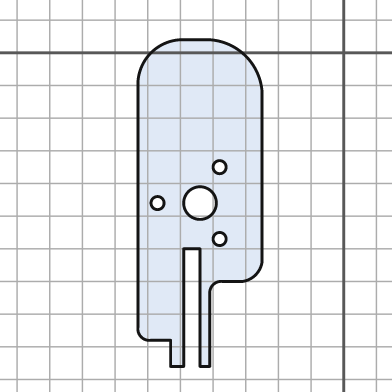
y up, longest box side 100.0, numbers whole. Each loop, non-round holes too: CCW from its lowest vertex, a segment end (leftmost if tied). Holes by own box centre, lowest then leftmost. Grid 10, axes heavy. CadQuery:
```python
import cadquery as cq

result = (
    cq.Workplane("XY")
    .moveTo(-53.0, -96.0)
    .lineTo(-49.0, -96.0)
    .lineTo(-49.0, -60.0)
    .lineTo(-44.0, -60.0)
    .lineTo(-44.0, -96.0)
    .lineTo(-41.0, -96.0)
    .lineTo(-41.0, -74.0)
    .threePointArc((-40.0, -71.0), (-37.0, -70.0))
    .lineTo(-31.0, -70.0)
    .threePointArc((-27.0, -68.0), (-25.0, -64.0))
    .lineTo(-25.0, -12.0)
    .threePointArc((-30.0, -1.0), (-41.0, 4.0))
    .lineTo(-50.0, 4.0)
    .threePointArc((-59.0, 0.0), (-63.0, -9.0))
    .lineTo(-63.0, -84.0)
    .threePointArc((-62.0, -87.0), (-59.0, -88.0))
    .lineTo(-53.0, -88.0)
    .close()
    .moveTo(-38.0, -57.0)
    .circle(2.0)
    .moveTo(-57.0, -46.0)
    .circle(2.0)
    .moveTo(-44.0, -46.0)
    .circle(5.0)
    .moveTo(-38.0, -35.0)
    .circle(2.0)
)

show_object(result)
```